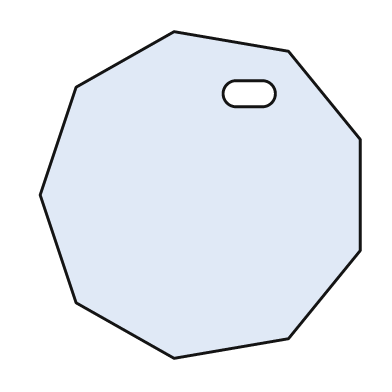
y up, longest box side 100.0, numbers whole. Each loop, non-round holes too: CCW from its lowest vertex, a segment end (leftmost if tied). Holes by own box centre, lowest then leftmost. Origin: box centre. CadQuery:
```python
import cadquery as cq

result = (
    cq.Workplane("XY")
    .moveTo(-8.0, -50.0)
    .lineTo(27.0, -44.0)
    .lineTo(49.0, -17.0)
    .lineTo(49.0, 17.0)
    .lineTo(27.0, 44.0)
    .lineTo(-8.0, 50.0)
    .lineTo(-38.0, 33.0)
    .lineTo(-49.0, 0.0)
    .lineTo(-38.0, -33.0)
    .close()
    .moveTo(11.0, 27.0)
    .lineTo(19.0, 27.0)
    .threePointArc((23.0, 31.0), (19.0, 35.0))
    .lineTo(11.0, 35.0)
    .threePointArc((7.0, 31.0), (11.0, 27.0))
    .close()
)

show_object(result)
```